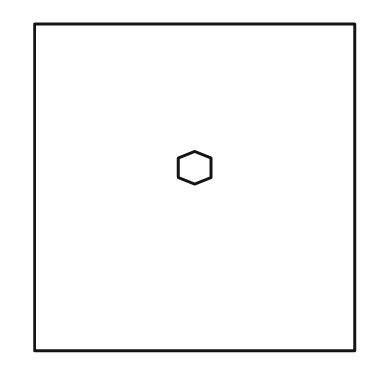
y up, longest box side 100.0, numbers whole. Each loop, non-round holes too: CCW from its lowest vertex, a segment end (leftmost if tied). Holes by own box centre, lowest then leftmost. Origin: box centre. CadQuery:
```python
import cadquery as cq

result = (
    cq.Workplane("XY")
    .moveTo(-49.0, -50.0)
    .lineTo(49.0, -50.0)
    .lineTo(49.0, 50.0)
    .lineTo(-49.0, 50.0)
    .close()
    .moveTo(0.0, 1.0)
    .lineTo(5.0, 3.0)
    .lineTo(5.0, 9.0)
    .lineTo(0.0, 11.0)
    .lineTo(-5.0, 9.0)
    .lineTo(-5.0, 3.0)
    .close()
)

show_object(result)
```